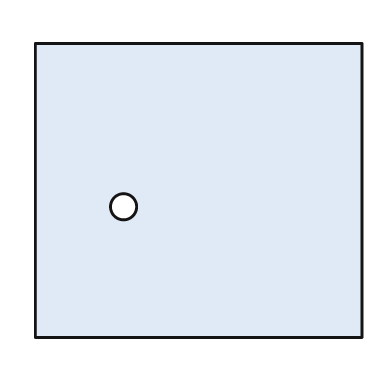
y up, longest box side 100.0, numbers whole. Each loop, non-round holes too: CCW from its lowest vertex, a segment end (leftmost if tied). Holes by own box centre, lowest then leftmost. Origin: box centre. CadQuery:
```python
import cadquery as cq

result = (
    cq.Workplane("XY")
    .moveTo(-50.0, -45.0)
    .lineTo(50.0, -45.0)
    .lineTo(50.0, 45.0)
    .lineTo(-50.0, 45.0)
    .close()
    .moveTo(-23.0, -5.0)
    .circle(4.0)
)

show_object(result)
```